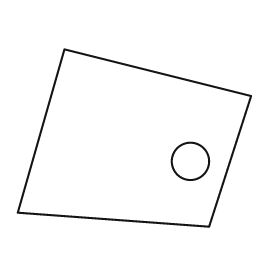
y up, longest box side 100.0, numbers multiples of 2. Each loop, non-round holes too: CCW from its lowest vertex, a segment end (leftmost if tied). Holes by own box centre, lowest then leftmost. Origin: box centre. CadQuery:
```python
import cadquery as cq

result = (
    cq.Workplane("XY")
    .moveTo(32.0, -38.0)
    .lineTo(50.0, 18.0)
    .lineTo(-30.0, 38.0)
    .lineTo(-50.0, -32.0)
    .close()
    .moveTo(24.0, -10.0)
    .circle(8.0)
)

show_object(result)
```